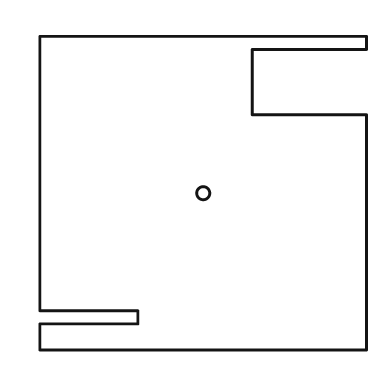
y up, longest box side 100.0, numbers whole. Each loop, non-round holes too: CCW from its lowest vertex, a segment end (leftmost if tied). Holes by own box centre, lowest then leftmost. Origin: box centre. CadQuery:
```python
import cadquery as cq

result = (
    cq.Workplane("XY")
    .moveTo(-50.0, -48.0)
    .lineTo(50.0, -48.0)
    .lineTo(50.0, 24.0)
    .lineTo(15.0, 24.0)
    .lineTo(15.0, 44.0)
    .lineTo(50.0, 44.0)
    .lineTo(50.0, 48.0)
    .lineTo(-50.0, 48.0)
    .lineTo(-50.0, -36.0)
    .lineTo(-20.0, -36.0)
    .lineTo(-20.0, -40.0)
    .lineTo(-50.0, -40.0)
    .close()
    .moveTo(0.0, 0.0)
    .circle(2.0)
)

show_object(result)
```